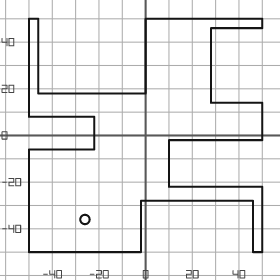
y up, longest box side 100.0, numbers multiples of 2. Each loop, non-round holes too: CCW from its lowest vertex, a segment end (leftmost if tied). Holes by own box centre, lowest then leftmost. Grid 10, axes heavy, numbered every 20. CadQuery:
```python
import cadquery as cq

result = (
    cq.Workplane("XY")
    .moveTo(-50.0, -50.0)
    .lineTo(-2.0, -50.0)
    .lineTo(-2.0, -28.0)
    .lineTo(46.0, -28.0)
    .lineTo(46.0, -50.0)
    .lineTo(50.0, -50.0)
    .lineTo(50.0, -22.0)
    .lineTo(10.0, -22.0)
    .lineTo(10.0, -2.0)
    .lineTo(50.0, -2.0)
    .lineTo(50.0, 14.0)
    .lineTo(28.0, 14.0)
    .lineTo(28.0, 46.0)
    .lineTo(50.0, 46.0)
    .lineTo(50.0, 50.0)
    .lineTo(0.0, 50.0)
    .lineTo(0.0, 18.0)
    .lineTo(-46.0, 18.0)
    .lineTo(-46.0, 50.0)
    .lineTo(-50.0, 50.0)
    .lineTo(-50.0, 8.0)
    .lineTo(-22.0, 8.0)
    .lineTo(-22.0, -6.0)
    .lineTo(-50.0, -6.0)
    .close()
    .moveTo(-26.0, -36.0)
    .circle(2.0)
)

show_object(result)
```